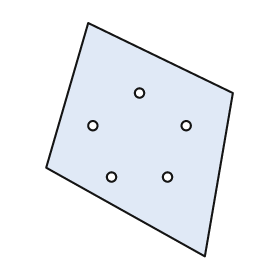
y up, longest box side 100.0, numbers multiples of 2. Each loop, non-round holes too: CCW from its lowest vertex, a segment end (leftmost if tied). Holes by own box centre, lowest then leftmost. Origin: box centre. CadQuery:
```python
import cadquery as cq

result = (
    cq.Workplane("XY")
    .moveTo(28.0, -50.0)
    .lineTo(40.0, 20.0)
    .lineTo(-22.0, 50.0)
    .lineTo(-40.0, -12.0)
    .close()
    .moveTo(-12.0, -16.0)
    .circle(2.0)
    .moveTo(12.0, -16.0)
    .circle(2.0)
    .moveTo(-20.0, 6.0)
    .circle(2.0)
    .moveTo(20.0, 6.0)
    .circle(2.0)
    .moveTo(0.0, 20.0)
    .circle(2.0)
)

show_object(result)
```